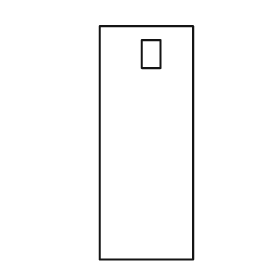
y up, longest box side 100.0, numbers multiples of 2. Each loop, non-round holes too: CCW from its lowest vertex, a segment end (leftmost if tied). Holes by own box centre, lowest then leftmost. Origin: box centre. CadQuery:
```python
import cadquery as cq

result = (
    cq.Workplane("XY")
    .moveTo(-20.0, -50.0)
    .lineTo(20.0, -50.0)
    .lineTo(20.0, 50.0)
    .lineTo(-20.0, 50.0)
    .close()
    .moveTo(-2.0, 32.0)
    .lineTo(6.0, 32.0)
    .lineTo(6.0, 44.0)
    .lineTo(-2.0, 44.0)
    .close()
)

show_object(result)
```